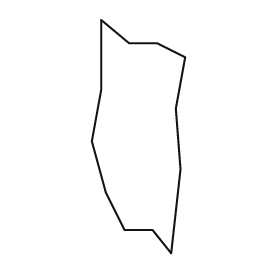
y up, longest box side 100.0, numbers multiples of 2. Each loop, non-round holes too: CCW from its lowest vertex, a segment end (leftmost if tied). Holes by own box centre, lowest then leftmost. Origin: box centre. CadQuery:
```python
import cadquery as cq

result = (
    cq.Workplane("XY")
    .moveTo(14.0, -50.0)
    .lineTo(18.0, -14.0)
    .lineTo(16.0, 12.0)
    .lineTo(20.0, 34.0)
    .lineTo(8.0, 40.0)
    .lineTo(-4.0, 40.0)
    .lineTo(-16.0, 50.0)
    .lineTo(-16.0, 20.0)
    .lineTo(-20.0, -2.0)
    .lineTo(-14.0, -24.0)
    .lineTo(-6.0, -40.0)
    .lineTo(6.0, -40.0)
    .close()
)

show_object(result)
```